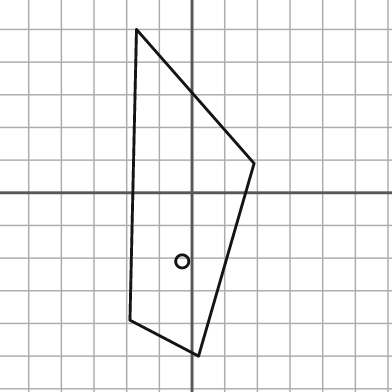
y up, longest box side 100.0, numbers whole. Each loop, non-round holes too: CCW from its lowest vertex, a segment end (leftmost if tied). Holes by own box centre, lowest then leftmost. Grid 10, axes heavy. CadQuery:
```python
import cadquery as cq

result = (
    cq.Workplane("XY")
    .moveTo(2.0, -50.0)
    .lineTo(19.0, 9.0)
    .lineTo(-17.0, 50.0)
    .lineTo(-19.0, -39.0)
    .close()
    .moveTo(-3.0, -21.0)
    .circle(2.0)
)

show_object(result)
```